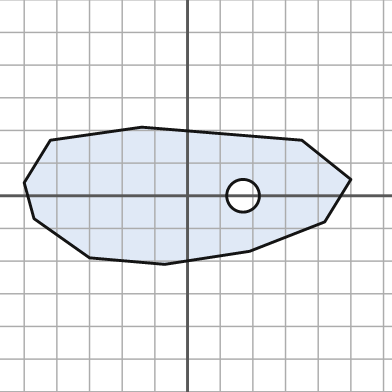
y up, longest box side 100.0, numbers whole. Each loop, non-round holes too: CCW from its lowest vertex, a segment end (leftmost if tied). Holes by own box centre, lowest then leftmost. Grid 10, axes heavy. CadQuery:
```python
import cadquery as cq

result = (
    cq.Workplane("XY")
    .moveTo(-7.0, -21.0)
    .lineTo(19.0, -17.0)
    .lineTo(42.0, -8.0)
    .lineTo(50.0, 5.0)
    .lineTo(35.0, 17.0)
    .lineTo(-14.0, 21.0)
    .lineTo(-42.0, 17.0)
    .lineTo(-50.0, 4.0)
    .lineTo(-47.0, -7.0)
    .lineTo(-30.0, -19.0)
    .close()
    .moveTo(17.0, 0.0)
    .circle(5.0)
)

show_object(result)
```